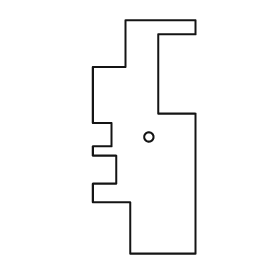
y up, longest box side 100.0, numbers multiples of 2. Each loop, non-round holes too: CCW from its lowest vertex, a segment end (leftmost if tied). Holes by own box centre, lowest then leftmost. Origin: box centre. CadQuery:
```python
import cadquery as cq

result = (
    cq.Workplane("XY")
    .moveTo(-6.0, -50.0)
    .lineTo(22.0, -50.0)
    .lineTo(22.0, 10.0)
    .lineTo(6.0, 10.0)
    .lineTo(6.0, 44.0)
    .lineTo(22.0, 44.0)
    .lineTo(22.0, 50.0)
    .lineTo(-8.0, 50.0)
    .lineTo(-8.0, 30.0)
    .lineTo(-22.0, 30.0)
    .lineTo(-22.0, 6.0)
    .lineTo(-14.0, 6.0)
    .lineTo(-14.0, -4.0)
    .lineTo(-22.0, -4.0)
    .lineTo(-22.0, -8.0)
    .lineTo(-12.0, -8.0)
    .lineTo(-12.0, -20.0)
    .lineTo(-22.0, -20.0)
    .lineTo(-22.0, -28.0)
    .lineTo(-6.0, -28.0)
    .close()
    .moveTo(2.0, 0.0)
    .circle(2.0)
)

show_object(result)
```